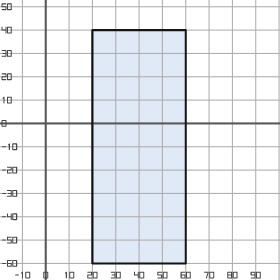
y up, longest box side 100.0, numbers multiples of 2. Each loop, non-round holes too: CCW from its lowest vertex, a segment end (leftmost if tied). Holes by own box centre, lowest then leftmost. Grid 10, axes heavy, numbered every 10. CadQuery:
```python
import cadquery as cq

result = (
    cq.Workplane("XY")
    .moveTo(20.0, -60.0)
    .lineTo(60.0, -60.0)
    .lineTo(60.0, 40.0)
    .lineTo(20.0, 40.0)
    .close()
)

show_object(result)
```